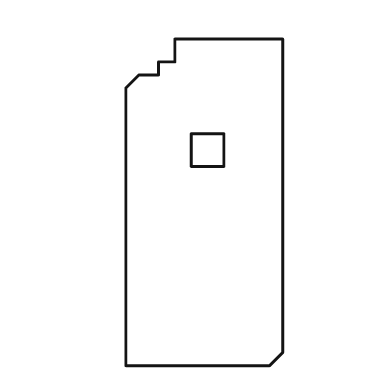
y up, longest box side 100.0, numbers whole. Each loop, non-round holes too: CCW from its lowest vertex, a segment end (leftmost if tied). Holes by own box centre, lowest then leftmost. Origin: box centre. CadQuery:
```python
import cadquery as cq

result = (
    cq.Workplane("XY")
    .moveTo(-24.0, -50.0)
    .lineTo(20.0, -50.0)
    .lineTo(24.0, -46.0)
    .lineTo(24.0, 50.0)
    .lineTo(-9.0, 50.0)
    .lineTo(-9.0, 43.0)
    .lineTo(-14.0, 43.0)
    .lineTo(-14.0, 39.0)
    .lineTo(-20.0, 39.0)
    .lineTo(-24.0, 35.0)
    .close()
    .moveTo(-4.0, 11.0)
    .lineTo(6.0, 11.0)
    .lineTo(6.0, 21.0)
    .lineTo(-4.0, 21.0)
    .close()
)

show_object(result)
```